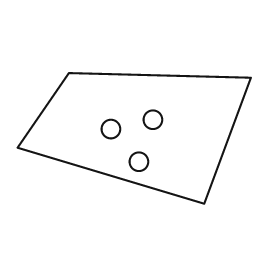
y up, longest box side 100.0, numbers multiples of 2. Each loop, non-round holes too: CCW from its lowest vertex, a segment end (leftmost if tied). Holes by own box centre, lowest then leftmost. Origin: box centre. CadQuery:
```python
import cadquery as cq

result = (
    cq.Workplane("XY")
    .moveTo(30.0, -28.0)
    .lineTo(50.0, 26.0)
    .lineTo(-28.0, 28.0)
    .lineTo(-50.0, -4.0)
    .close()
    .moveTo(2.0, -10.0)
    .circle(4.0)
    .moveTo(-10.0, 4.0)
    .circle(4.0)
    .moveTo(8.0, 8.0)
    .circle(4.0)
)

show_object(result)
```